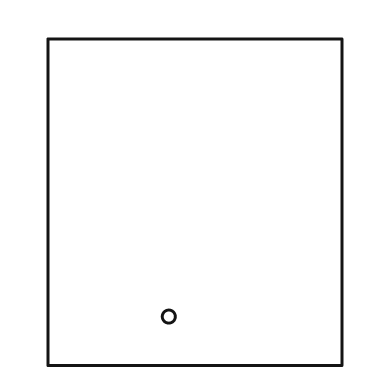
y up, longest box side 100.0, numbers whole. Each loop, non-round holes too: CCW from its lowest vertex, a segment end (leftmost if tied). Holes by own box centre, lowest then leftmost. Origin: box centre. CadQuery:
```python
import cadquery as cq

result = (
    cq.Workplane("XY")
    .moveTo(-45.0, -50.0)
    .lineTo(45.0, -50.0)
    .lineTo(45.0, 50.0)
    .lineTo(-45.0, 50.0)
    .close()
    .moveTo(-8.0, -35.0)
    .circle(2.0)
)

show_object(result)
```